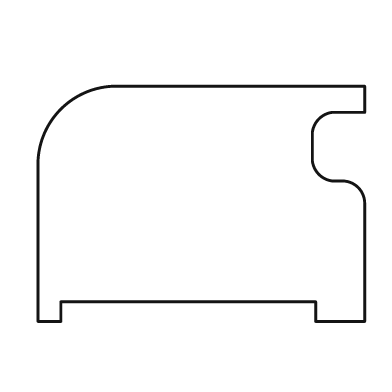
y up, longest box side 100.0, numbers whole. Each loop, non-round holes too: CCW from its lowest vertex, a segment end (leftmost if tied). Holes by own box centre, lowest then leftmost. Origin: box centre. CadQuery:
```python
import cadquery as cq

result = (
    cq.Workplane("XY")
    .moveTo(-50.0, -36.0)
    .lineTo(-43.0, -36.0)
    .lineTo(-43.0, -30.0)
    .lineTo(35.0, -30.0)
    .lineTo(35.0, -36.0)
    .lineTo(50.0, -36.0)
    .lineTo(50.0, 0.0)
    .threePointArc((48.0, 5.0), (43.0, 7.0))
    .lineTo(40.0, 7.0)
    .threePointArc((36.0, 9.0), (34.0, 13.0))
    .lineTo(34.0, 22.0)
    .threePointArc((36.0, 26.0), (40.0, 28.0))
    .lineTo(50.0, 28.0)
    .lineTo(50.0, 36.0)
    .lineTo(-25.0, 36.0)
    .threePointArc((-43.0, 29.0), (-50.0, 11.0))
    .close()
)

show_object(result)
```